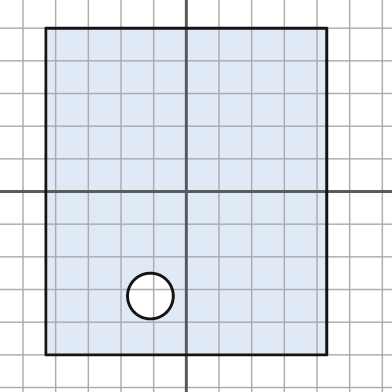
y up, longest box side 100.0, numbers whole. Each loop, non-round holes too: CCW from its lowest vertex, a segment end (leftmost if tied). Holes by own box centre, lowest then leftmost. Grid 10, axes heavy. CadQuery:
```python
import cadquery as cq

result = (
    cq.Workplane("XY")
    .moveTo(-43.0, -50.0)
    .lineTo(43.0, -50.0)
    .lineTo(43.0, 50.0)
    .lineTo(-43.0, 50.0)
    .close()
    .moveTo(-11.0, -32.0)
    .circle(7.0)
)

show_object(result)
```